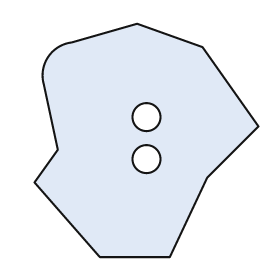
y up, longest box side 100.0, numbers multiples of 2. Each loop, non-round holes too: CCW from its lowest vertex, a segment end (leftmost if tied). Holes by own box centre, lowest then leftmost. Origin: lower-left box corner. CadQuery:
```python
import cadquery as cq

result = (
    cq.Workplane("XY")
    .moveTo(28.0, 0.0)
    .lineTo(58.0, 0.0)
    .lineTo(74.0, 34.0)
    .lineTo(96.0, 56.0)
    .lineTo(72.0, 90.0)
    .lineTo(44.0, 100.0)
    .lineTo(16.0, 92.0)
    .threePointArc((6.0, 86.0), (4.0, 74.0))
    .lineTo(10.0, 46.0)
    .lineTo(0.0, 32.0)
    .close()
    .moveTo(48.0, 42.0)
    .circle(6.0)
    .moveTo(48.0, 60.0)
    .circle(6.0)
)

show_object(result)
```